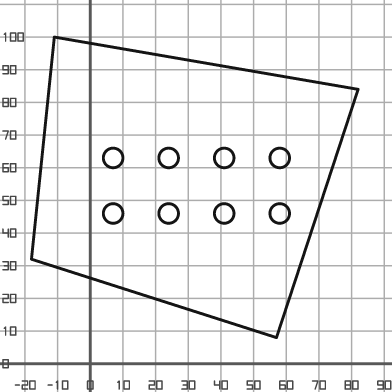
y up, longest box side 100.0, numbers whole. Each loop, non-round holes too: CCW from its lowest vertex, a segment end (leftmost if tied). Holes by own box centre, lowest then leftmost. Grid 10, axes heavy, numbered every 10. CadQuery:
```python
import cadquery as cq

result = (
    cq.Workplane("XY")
    .moveTo(57.0, 8.0)
    .lineTo(82.0, 84.0)
    .lineTo(-11.0, 100.0)
    .lineTo(-18.0, 32.0)
    .close()
    .moveTo(7.0, 46.0)
    .circle(3.0)
    .moveTo(24.0, 46.0)
    .circle(3.0)
    .moveTo(41.0, 46.0)
    .circle(3.0)
    .moveTo(58.0, 46.0)
    .circle(3.0)
    .moveTo(7.0, 63.0)
    .circle(3.0)
    .moveTo(24.0, 63.0)
    .circle(3.0)
    .moveTo(41.0, 63.0)
    .circle(3.0)
    .moveTo(58.0, 63.0)
    .circle(3.0)
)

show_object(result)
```